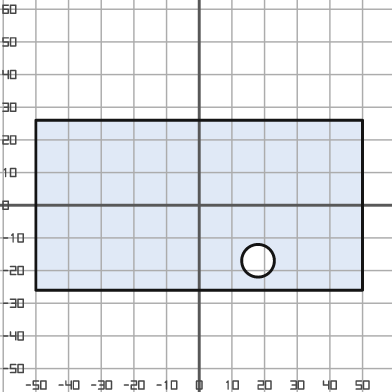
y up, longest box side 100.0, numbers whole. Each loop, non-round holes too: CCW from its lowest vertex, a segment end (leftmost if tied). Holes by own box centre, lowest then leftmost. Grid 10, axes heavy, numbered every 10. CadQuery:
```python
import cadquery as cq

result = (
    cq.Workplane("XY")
    .moveTo(-50.0, -26.0)
    .lineTo(50.0, -26.0)
    .lineTo(50.0, 26.0)
    .lineTo(-50.0, 26.0)
    .close()
    .moveTo(18.0, -17.0)
    .circle(5.0)
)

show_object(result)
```